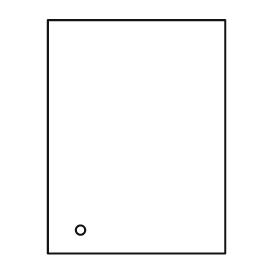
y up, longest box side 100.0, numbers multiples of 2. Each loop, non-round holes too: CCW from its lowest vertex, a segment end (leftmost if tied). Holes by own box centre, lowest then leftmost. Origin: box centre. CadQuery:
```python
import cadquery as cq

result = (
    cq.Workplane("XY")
    .moveTo(-38.0, -50.0)
    .lineTo(38.0, -50.0)
    .lineTo(38.0, 50.0)
    .lineTo(-38.0, 50.0)
    .close()
    .moveTo(-24.0, -40.0)
    .circle(2.0)
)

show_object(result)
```